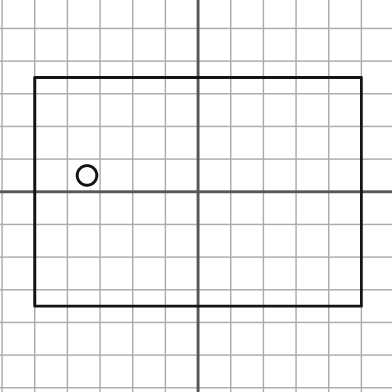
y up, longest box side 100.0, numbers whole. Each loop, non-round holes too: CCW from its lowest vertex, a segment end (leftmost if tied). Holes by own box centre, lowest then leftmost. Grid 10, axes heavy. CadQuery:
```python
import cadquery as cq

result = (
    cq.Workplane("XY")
    .moveTo(-50.0, -35.0)
    .lineTo(50.0, -35.0)
    .lineTo(50.0, 35.0)
    .lineTo(-50.0, 35.0)
    .close()
    .moveTo(-34.0, 5.0)
    .circle(3.0)
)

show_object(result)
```